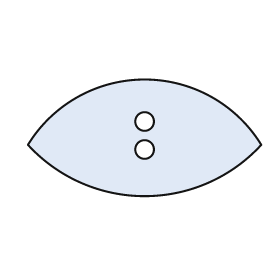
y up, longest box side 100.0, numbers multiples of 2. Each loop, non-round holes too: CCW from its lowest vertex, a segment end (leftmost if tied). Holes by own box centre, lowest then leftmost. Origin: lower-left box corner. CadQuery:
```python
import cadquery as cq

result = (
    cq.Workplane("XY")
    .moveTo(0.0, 22.0)
    .threePointArc((50.0, 0.0), (100.0, 22.0))
    .threePointArc((50.0, 50.0), (0.0, 22.0))
    .close()
    .moveTo(50.0, 20.0)
    .circle(4.0)
    .moveTo(50.0, 32.0)
    .circle(4.0)
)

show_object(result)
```